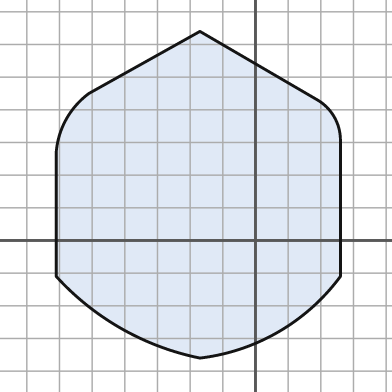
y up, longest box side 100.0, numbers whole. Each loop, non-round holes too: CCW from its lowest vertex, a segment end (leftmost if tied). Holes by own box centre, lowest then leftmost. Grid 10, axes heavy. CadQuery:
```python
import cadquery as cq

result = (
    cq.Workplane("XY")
    .moveTo(-17.0, -36.0)
    .threePointArc((7.0, -28.0), (26.0, -11.0))
    .lineTo(26.0, 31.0)
    .threePointArc((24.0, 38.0), (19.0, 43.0))
    .lineTo(-17.0, 64.0)
    .lineTo(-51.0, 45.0)
    .threePointArc((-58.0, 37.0), (-61.0, 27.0))
    .lineTo(-61.0, -11.0)
    .threePointArc((-41.0, -27.0), (-17.0, -36.0))
    .close()
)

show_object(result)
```